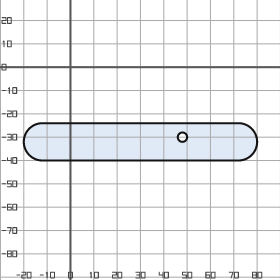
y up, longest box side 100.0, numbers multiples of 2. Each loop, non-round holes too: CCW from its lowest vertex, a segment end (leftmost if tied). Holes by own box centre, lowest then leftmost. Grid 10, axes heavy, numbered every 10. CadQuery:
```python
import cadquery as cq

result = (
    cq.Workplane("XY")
    .moveTo(-12.0, -40.0)
    .lineTo(72.0, -40.0)
    .threePointArc((80.0, -32.0), (72.0, -24.0))
    .lineTo(-12.0, -24.0)
    .threePointArc((-20.0, -32.0), (-12.0, -40.0))
    .close()
    .moveTo(48.0, -30.0)
    .circle(2.0)
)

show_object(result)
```